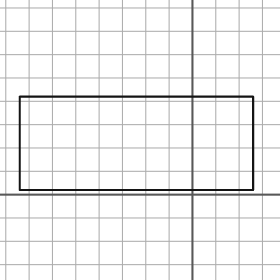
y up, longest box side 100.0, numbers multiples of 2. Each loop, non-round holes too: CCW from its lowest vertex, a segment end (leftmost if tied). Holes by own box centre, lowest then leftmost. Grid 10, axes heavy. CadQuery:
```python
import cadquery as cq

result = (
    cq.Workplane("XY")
    .moveTo(-74.0, 2.0)
    .lineTo(26.0, 2.0)
    .lineTo(26.0, 42.0)
    .lineTo(-74.0, 42.0)
    .close()
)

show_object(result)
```